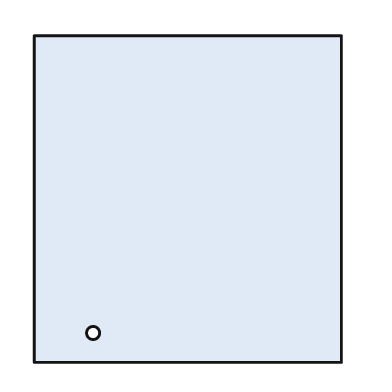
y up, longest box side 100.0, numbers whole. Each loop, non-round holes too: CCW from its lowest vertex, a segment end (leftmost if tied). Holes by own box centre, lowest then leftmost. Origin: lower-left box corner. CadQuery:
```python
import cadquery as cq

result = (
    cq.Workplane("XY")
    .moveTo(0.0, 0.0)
    .lineTo(94.0, 0.0)
    .lineTo(94.0, 100.0)
    .lineTo(0.0, 100.0)
    .close()
    .moveTo(18.0, 9.0)
    .circle(2.0)
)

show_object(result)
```